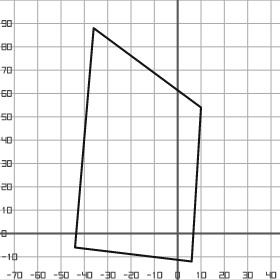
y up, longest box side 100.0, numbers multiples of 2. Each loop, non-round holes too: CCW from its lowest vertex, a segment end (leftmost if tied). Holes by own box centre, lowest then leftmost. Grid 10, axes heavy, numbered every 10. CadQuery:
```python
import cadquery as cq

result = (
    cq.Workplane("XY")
    .moveTo(6.0, -12.0)
    .lineTo(10.0, 54.0)
    .lineTo(-36.0, 88.0)
    .lineTo(-44.0, -6.0)
    .close()
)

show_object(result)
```